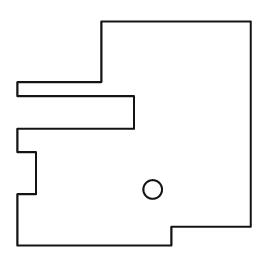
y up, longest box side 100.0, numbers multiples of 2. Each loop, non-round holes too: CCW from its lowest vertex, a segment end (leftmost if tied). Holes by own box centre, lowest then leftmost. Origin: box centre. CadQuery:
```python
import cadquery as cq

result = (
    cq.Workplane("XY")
    .moveTo(-50.0, -48.0)
    .lineTo(16.0, -48.0)
    .lineTo(16.0, -40.0)
    .lineTo(50.0, -40.0)
    .lineTo(50.0, 48.0)
    .lineTo(-14.0, 48.0)
    .lineTo(-14.0, 22.0)
    .lineTo(-50.0, 22.0)
    .lineTo(-50.0, 16.0)
    .lineTo(0.0, 16.0)
    .lineTo(0.0, 2.0)
    .lineTo(-50.0, 2.0)
    .lineTo(-50.0, -8.0)
    .lineTo(-42.0, -8.0)
    .lineTo(-42.0, -26.0)
    .lineTo(-50.0, -26.0)
    .close()
    .moveTo(8.0, -24.0)
    .circle(4.0)
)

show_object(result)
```